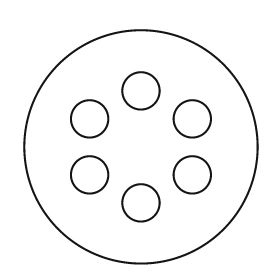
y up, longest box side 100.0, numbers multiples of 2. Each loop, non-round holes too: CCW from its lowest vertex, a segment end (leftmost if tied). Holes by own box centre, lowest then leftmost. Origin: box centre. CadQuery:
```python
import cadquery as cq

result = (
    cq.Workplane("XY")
    .moveTo(0.0, 0.0)
    .circle(50.0)
    .moveTo(0.0, -24.0)
    .circle(8.0)
    .moveTo(-22.0, -12.0)
    .circle(8.0)
    .moveTo(22.0, -12.0)
    .circle(8.0)
    .moveTo(-22.0, 12.0)
    .circle(8.0)
    .moveTo(22.0, 12.0)
    .circle(8.0)
    .moveTo(0.0, 24.0)
    .circle(8.0)
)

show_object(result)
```